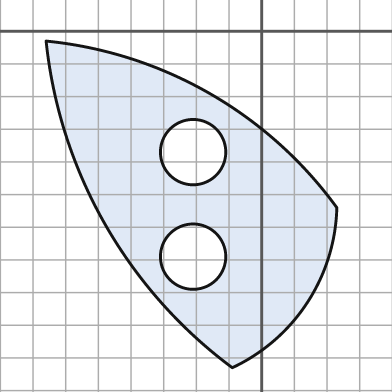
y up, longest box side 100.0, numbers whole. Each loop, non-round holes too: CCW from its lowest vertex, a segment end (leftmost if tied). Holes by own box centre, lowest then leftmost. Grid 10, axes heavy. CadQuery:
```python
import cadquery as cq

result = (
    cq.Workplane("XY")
    .moveTo(-9.0, -103.0)
    .threePointArc((14.0, -83.0), (23.0, -54.0))
    .threePointArc((-16.0, -19.0), (-66.0, -3.0))
    .threePointArc((-48.0, -59.0), (-9.0, -103.0))
    .close()
    .moveTo(-21.0, -69.0)
    .circle(10.0)
    .moveTo(-21.0, -37.0)
    .circle(10.0)
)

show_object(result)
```